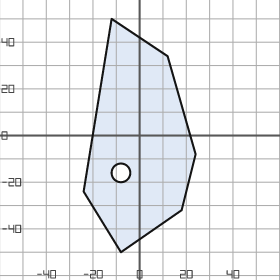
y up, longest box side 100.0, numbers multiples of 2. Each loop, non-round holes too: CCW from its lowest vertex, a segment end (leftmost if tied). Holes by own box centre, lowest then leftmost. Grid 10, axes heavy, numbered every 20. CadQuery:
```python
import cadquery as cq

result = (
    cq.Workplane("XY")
    .moveTo(-8.0, -50.0)
    .lineTo(18.0, -32.0)
    .lineTo(24.0, -8.0)
    .lineTo(12.0, 34.0)
    .lineTo(-12.0, 50.0)
    .lineTo(-24.0, -24.0)
    .close()
    .moveTo(-8.0, -16.0)
    .circle(4.0)
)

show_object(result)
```